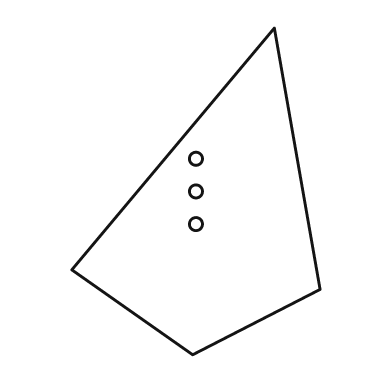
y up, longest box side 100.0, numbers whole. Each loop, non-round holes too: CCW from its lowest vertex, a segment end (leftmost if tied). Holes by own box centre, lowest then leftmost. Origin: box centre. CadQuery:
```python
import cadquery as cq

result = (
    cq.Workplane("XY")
    .moveTo(-1.0, -50.0)
    .lineTo(38.0, -30.0)
    .lineTo(24.0, 50.0)
    .lineTo(-38.0, -24.0)
    .close()
    .moveTo(0.0, -10.0)
    .circle(2.0)
    .moveTo(0.0, 0.0)
    .circle(2.0)
    .moveTo(0.0, 10.0)
    .circle(2.0)
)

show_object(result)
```